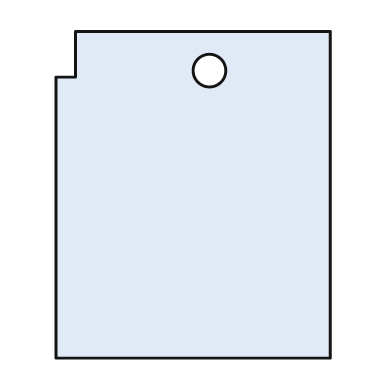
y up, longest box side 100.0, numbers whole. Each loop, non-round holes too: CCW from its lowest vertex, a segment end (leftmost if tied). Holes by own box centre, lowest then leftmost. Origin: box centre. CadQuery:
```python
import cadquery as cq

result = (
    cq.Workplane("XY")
    .moveTo(-42.0, -50.0)
    .lineTo(42.0, -50.0)
    .lineTo(42.0, 50.0)
    .lineTo(-36.0, 50.0)
    .lineTo(-36.0, 36.0)
    .lineTo(-42.0, 36.0)
    .close()
    .moveTo(5.0, 38.0)
    .circle(5.0)
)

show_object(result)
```